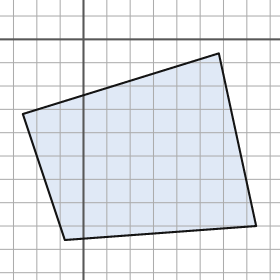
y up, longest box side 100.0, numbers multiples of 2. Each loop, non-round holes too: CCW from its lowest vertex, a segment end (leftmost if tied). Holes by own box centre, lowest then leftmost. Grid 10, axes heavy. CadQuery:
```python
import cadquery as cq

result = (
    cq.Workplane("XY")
    .moveTo(-8.0, -86.0)
    .lineTo(74.0, -80.0)
    .lineTo(58.0, -6.0)
    .lineTo(-26.0, -32.0)
    .close()
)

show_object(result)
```